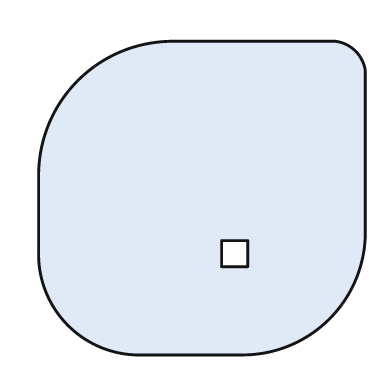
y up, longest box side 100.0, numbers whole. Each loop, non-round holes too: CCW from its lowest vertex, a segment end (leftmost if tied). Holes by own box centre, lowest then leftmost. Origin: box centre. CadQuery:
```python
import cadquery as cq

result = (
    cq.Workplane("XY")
    .moveTo(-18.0, -48.0)
    .lineTo(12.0, -48.0)
    .threePointArc((39.0, -37.0), (50.0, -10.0))
    .lineTo(50.0, 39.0)
    .threePointArc((47.0, 45.0), (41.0, 48.0))
    .lineTo(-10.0, 48.0)
    .threePointArc((-38.0, 36.0), (-50.0, 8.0))
    .lineTo(-50.0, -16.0)
    .threePointArc((-41.0, -39.0), (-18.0, -48.0))
    .close()
    .moveTo(6.0, -21.0)
    .lineTo(14.0, -21.0)
    .lineTo(14.0, -13.0)
    .lineTo(6.0, -13.0)
    .close()
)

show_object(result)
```